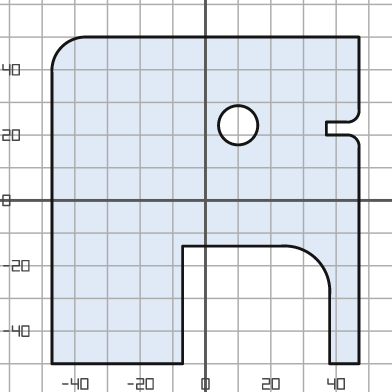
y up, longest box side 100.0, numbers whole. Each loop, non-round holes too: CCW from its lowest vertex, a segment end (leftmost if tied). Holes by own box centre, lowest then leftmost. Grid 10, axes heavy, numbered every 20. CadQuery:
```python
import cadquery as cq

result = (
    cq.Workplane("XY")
    .moveTo(-47.0, -50.0)
    .lineTo(-7.0, -50.0)
    .lineTo(-7.0, -14.0)
    .lineTo(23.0, -14.0)
    .threePointArc((34.0, -18.0), (38.0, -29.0))
    .lineTo(38.0, -50.0)
    .lineTo(47.0, -50.0)
    .lineTo(47.0, 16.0)
    .threePointArc((46.0, 19.0), (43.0, 20.0))
    .lineTo(37.0, 20.0)
    .lineTo(37.0, 24.0)
    .lineTo(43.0, 24.0)
    .threePointArc((46.0, 25.0), (47.0, 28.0))
    .lineTo(47.0, 50.0)
    .lineTo(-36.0, 50.0)
    .threePointArc((-44.0, 47.0), (-47.0, 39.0))
    .close()
    .moveTo(10.0, 23.0)
    .circle(6.0)
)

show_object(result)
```